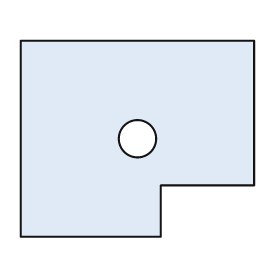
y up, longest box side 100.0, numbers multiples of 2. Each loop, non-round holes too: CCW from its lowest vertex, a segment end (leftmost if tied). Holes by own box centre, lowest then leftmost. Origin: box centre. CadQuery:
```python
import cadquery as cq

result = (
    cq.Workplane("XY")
    .moveTo(-50.0, -42.0)
    .lineTo(10.0, -42.0)
    .lineTo(10.0, -20.0)
    .lineTo(50.0, -20.0)
    .lineTo(50.0, 42.0)
    .lineTo(-50.0, 42.0)
    .close()
    .moveTo(0.0, 0.0)
    .circle(8.0)
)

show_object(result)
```